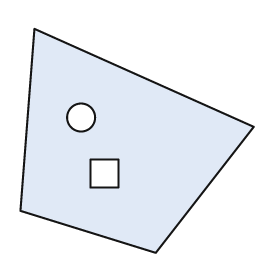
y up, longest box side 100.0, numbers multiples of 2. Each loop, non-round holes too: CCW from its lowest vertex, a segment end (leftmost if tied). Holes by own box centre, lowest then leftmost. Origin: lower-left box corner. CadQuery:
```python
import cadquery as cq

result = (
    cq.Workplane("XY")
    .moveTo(58.0, 0.0)
    .lineTo(100.0, 54.0)
    .lineTo(6.0, 96.0)
    .lineTo(0.0, 18.0)
    .close()
    .moveTo(30.0, 28.0)
    .lineTo(42.0, 28.0)
    .lineTo(42.0, 40.0)
    .lineTo(30.0, 40.0)
    .close()
    .moveTo(26.0, 58.0)
    .circle(6.0)
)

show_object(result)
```